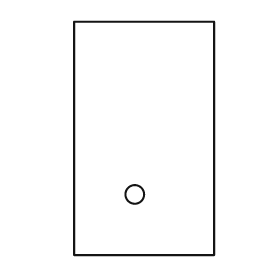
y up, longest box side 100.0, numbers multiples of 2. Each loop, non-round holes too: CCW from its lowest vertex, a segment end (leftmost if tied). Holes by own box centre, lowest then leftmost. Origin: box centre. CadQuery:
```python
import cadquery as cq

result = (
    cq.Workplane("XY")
    .moveTo(-30.0, -50.0)
    .lineTo(30.0, -50.0)
    .lineTo(30.0, 50.0)
    .lineTo(-30.0, 50.0)
    .close()
    .moveTo(-4.0, -24.0)
    .circle(4.0)
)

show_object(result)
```